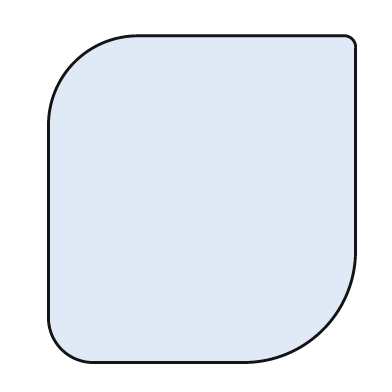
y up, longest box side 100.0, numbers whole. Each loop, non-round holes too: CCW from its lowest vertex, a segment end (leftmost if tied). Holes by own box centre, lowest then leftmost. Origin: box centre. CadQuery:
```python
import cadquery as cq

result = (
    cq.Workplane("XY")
    .moveTo(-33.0, -50.0)
    .lineTo(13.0, -50.0)
    .threePointArc((37.0, -40.0), (47.0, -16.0))
    .lineTo(47.0, 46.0)
    .threePointArc((46.0, 49.0), (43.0, 50.0))
    .lineTo(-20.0, 50.0)
    .threePointArc((-39.0, 42.0), (-47.0, 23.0))
    .lineTo(-47.0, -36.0)
    .threePointArc((-43.0, -46.0), (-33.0, -50.0))
    .close()
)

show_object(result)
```